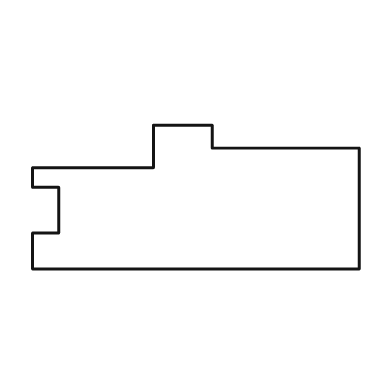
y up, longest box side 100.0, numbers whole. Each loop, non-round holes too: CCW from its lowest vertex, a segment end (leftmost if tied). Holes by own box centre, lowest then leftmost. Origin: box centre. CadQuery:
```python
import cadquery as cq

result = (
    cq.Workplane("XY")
    .moveTo(-50.0, -22.0)
    .lineTo(50.0, -22.0)
    .lineTo(50.0, 15.0)
    .lineTo(5.0, 15.0)
    .lineTo(5.0, 22.0)
    .lineTo(-13.0, 22.0)
    .lineTo(-13.0, 9.0)
    .lineTo(-50.0, 9.0)
    .lineTo(-50.0, 3.0)
    .lineTo(-42.0, 3.0)
    .lineTo(-42.0, -11.0)
    .lineTo(-50.0, -11.0)
    .close()
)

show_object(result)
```